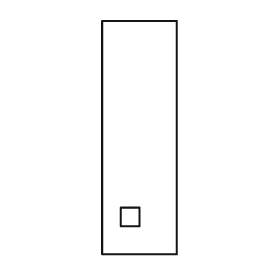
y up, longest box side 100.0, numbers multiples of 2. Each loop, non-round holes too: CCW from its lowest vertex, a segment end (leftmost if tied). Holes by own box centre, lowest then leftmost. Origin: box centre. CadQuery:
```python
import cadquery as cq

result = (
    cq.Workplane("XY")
    .moveTo(-16.0, -50.0)
    .lineTo(16.0, -50.0)
    .lineTo(16.0, 50.0)
    .lineTo(-16.0, 50.0)
    .close()
    .moveTo(-8.0, -38.0)
    .lineTo(0.0, -38.0)
    .lineTo(0.0, -30.0)
    .lineTo(-8.0, -30.0)
    .close()
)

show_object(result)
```